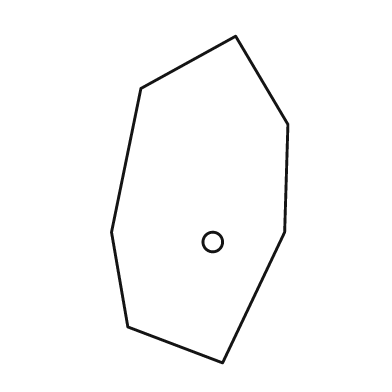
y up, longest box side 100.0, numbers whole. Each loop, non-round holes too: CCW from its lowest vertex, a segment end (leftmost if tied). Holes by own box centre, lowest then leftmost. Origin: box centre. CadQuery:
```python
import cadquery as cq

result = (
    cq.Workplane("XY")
    .moveTo(7.0, -50.0)
    .lineTo(26.0, -10.0)
    .lineTo(27.0, 23.0)
    .lineTo(11.0, 50.0)
    .lineTo(-18.0, 34.0)
    .lineTo(-27.0, -10.0)
    .lineTo(-22.0, -39.0)
    .close()
    .moveTo(4.0, -13.0)
    .circle(3.0)
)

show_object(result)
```